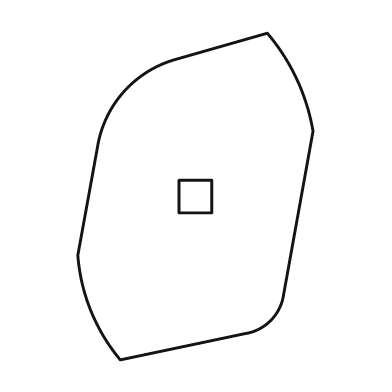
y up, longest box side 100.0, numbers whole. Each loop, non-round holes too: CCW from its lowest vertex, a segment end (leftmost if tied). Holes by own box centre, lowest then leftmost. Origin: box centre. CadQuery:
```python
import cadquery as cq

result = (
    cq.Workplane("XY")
    .moveTo(-23.0, -50.0)
    .lineTo(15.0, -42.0)
    .threePointArc((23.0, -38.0), (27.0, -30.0))
    .lineTo(36.0, 20.0)
    .threePointArc((31.0, 36.0), (22.0, 50.0))
    .lineTo(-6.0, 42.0)
    .threePointArc((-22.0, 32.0), (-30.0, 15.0))
    .lineTo(-36.0, -18.0)
    .threePointArc((-32.0, -35.0), (-23.0, -50.0))
    .close()
    .moveTo(-5.0, -5.0)
    .lineTo(5.0, -5.0)
    .lineTo(5.0, 5.0)
    .lineTo(-5.0, 5.0)
    .close()
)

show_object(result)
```